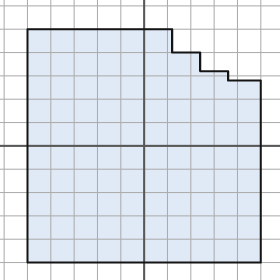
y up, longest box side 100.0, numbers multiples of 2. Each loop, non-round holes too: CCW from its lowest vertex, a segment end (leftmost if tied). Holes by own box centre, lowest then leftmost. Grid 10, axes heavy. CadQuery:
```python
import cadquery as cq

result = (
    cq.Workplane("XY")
    .moveTo(-50.0, -50.0)
    .lineTo(50.0, -50.0)
    .lineTo(50.0, 28.0)
    .lineTo(36.0, 28.0)
    .lineTo(36.0, 32.0)
    .lineTo(24.0, 32.0)
    .lineTo(24.0, 40.0)
    .lineTo(12.0, 40.0)
    .lineTo(12.0, 50.0)
    .lineTo(-50.0, 50.0)
    .close()
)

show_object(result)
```